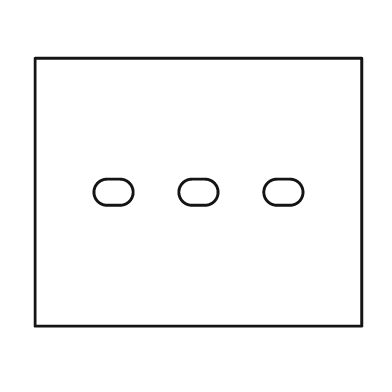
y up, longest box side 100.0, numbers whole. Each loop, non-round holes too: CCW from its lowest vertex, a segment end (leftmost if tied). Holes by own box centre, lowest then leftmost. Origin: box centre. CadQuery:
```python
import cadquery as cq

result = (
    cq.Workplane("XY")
    .moveTo(-50.0, -41.0)
    .lineTo(50.0, -41.0)
    .lineTo(50.0, 41.0)
    .lineTo(-50.0, 41.0)
    .close()
    .moveTo(-28.0, -4.0)
    .lineTo(-24.0, -4.0)
    .threePointArc((-20.0, 0.0), (-24.0, 4.0))
    .lineTo(-28.0, 4.0)
    .threePointArc((-32.0, 0.0), (-28.0, -4.0))
    .close()
    .moveTo(-2.0, -4.0)
    .lineTo(2.0, -4.0)
    .threePointArc((6.0, 0.0), (2.0, 4.0))
    .lineTo(-2.0, 4.0)
    .threePointArc((-6.0, 0.0), (-2.0, -4.0))
    .close()
    .moveTo(24.0, -4.0)
    .lineTo(28.0, -4.0)
    .threePointArc((32.0, 0.0), (28.0, 4.0))
    .lineTo(24.0, 4.0)
    .threePointArc((20.0, 0.0), (24.0, -4.0))
    .close()
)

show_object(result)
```